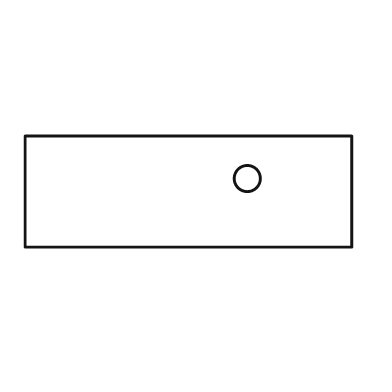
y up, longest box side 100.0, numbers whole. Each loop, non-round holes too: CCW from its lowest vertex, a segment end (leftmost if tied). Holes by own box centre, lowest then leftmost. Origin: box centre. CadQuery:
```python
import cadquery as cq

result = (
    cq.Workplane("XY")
    .moveTo(-50.0, -17.0)
    .lineTo(50.0, -17.0)
    .lineTo(50.0, 17.0)
    .lineTo(-50.0, 17.0)
    .close()
    .moveTo(18.0, 4.0)
    .circle(4.0)
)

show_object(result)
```